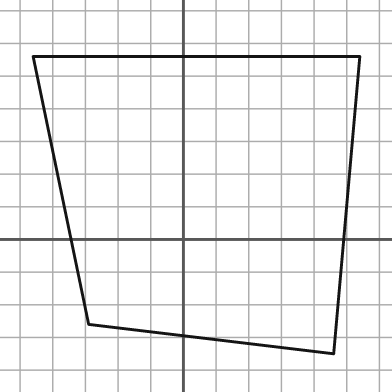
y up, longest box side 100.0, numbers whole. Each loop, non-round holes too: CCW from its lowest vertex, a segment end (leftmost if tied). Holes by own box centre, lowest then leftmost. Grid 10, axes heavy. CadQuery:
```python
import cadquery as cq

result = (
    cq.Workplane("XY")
    .moveTo(46.0, -35.0)
    .lineTo(54.0, 56.0)
    .lineTo(-46.0, 56.0)
    .lineTo(-29.0, -26.0)
    .close()
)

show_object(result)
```